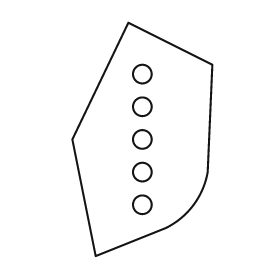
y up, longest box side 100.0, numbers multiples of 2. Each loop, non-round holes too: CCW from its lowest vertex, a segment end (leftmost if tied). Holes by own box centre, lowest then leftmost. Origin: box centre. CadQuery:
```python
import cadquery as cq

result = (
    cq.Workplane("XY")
    .moveTo(-20.0, -50.0)
    .lineTo(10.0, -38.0)
    .threePointArc((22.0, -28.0), (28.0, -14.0))
    .lineTo(30.0, 32.0)
    .lineTo(-6.0, 50.0)
    .lineTo(-30.0, 0.0)
    .close()
    .moveTo(0.0, -28.0)
    .circle(4.0)
    .moveTo(0.0, -14.0)
    .circle(4.0)
    .moveTo(0.0, 0.0)
    .circle(4.0)
    .moveTo(0.0, 14.0)
    .circle(4.0)
    .moveTo(0.0, 28.0)
    .circle(4.0)
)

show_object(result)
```